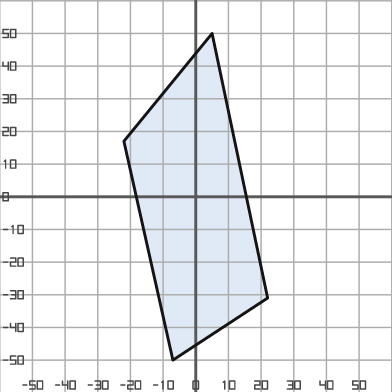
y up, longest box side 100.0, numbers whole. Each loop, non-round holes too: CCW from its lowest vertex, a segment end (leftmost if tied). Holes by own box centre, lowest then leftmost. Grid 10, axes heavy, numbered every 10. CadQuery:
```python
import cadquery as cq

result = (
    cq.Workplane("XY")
    .moveTo(-7.0, -50.0)
    .lineTo(22.0, -31.0)
    .lineTo(5.0, 50.0)
    .lineTo(-22.0, 17.0)
    .close()
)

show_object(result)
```